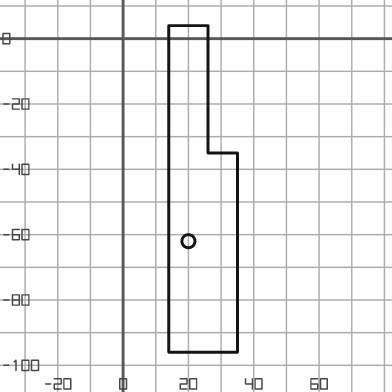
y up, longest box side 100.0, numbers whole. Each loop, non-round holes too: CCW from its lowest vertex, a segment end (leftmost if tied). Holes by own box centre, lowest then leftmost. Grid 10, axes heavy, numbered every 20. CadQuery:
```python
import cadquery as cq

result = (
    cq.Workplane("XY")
    .moveTo(14.0, -96.0)
    .lineTo(35.0, -96.0)
    .lineTo(35.0, -35.0)
    .lineTo(26.0, -35.0)
    .lineTo(26.0, 4.0)
    .lineTo(14.0, 4.0)
    .close()
    .moveTo(20.0, -62.0)
    .circle(2.0)
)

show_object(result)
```